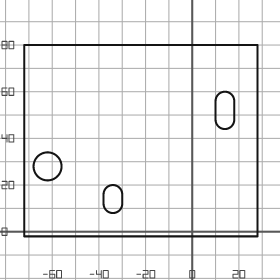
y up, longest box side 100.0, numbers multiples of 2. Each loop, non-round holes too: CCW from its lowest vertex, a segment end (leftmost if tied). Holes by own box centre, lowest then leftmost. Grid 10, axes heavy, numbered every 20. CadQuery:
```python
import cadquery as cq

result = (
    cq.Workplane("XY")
    .moveTo(-72.0, -2.0)
    .lineTo(28.0, -2.0)
    .lineTo(28.0, 80.0)
    .lineTo(-72.0, 80.0)
    .close()
    .moveTo(-38.0, 12.0)
    .threePointArc((-34.0, 8.0), (-30.0, 12.0))
    .lineTo(-30.0, 16.0)
    .threePointArc((-34.0, 20.0), (-38.0, 16.0))
    .close()
    .moveTo(-62.0, 28.0)
    .circle(6.0)
    .moveTo(10.0, 48.0)
    .threePointArc((14.0, 44.0), (18.0, 48.0))
    .lineTo(18.0, 56.0)
    .threePointArc((14.0, 60.0), (10.0, 56.0))
    .close()
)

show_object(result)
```